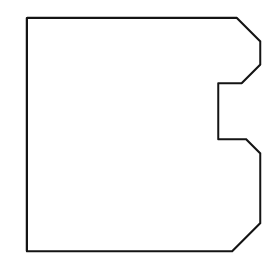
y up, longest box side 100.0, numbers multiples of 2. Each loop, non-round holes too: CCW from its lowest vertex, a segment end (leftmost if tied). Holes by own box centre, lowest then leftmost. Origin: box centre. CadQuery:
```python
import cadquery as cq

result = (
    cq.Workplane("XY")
    .moveTo(-50.0, -50.0)
    .lineTo(38.0, -50.0)
    .lineTo(50.0, -38.0)
    .lineTo(50.0, -8.0)
    .lineTo(44.0, -2.0)
    .lineTo(32.0, -2.0)
    .lineTo(32.0, 22.0)
    .lineTo(42.0, 22.0)
    .lineTo(50.0, 30.0)
    .lineTo(50.0, 40.0)
    .lineTo(40.0, 50.0)
    .lineTo(-50.0, 50.0)
    .close()
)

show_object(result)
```